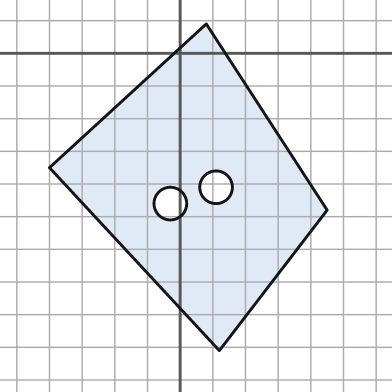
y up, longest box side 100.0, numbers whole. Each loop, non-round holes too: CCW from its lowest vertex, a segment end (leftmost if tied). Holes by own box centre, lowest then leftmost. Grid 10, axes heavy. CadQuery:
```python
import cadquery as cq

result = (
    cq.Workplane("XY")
    .moveTo(12.0, -91.0)
    .lineTo(45.0, -48.0)
    .lineTo(8.0, 9.0)
    .lineTo(-40.0, -35.0)
    .close()
    .moveTo(-3.0, -46.0)
    .circle(5.0)
    .moveTo(11.0, -41.0)
    .circle(5.0)
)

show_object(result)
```